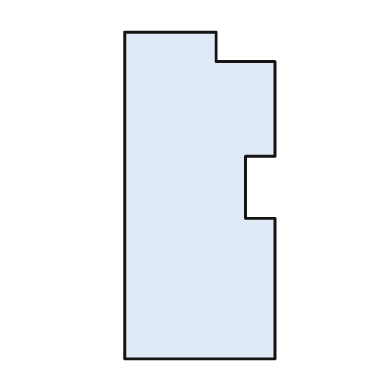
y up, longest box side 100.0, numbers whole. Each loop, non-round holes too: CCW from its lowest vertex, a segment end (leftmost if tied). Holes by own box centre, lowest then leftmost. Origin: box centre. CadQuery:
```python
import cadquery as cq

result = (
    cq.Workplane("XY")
    .moveTo(-23.0, -50.0)
    .lineTo(23.0, -50.0)
    .lineTo(23.0, -7.0)
    .lineTo(14.0, -7.0)
    .lineTo(14.0, 12.0)
    .lineTo(23.0, 12.0)
    .lineTo(23.0, 41.0)
    .lineTo(5.0, 41.0)
    .lineTo(5.0, 50.0)
    .lineTo(-23.0, 50.0)
    .close()
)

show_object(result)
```